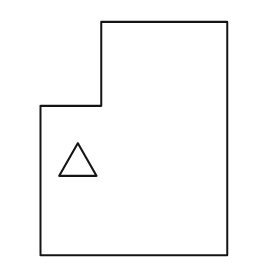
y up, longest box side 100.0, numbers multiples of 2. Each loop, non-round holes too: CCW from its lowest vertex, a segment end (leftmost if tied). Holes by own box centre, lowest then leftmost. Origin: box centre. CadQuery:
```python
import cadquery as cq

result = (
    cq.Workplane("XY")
    .moveTo(-40.0, -50.0)
    .lineTo(40.0, -50.0)
    .lineTo(40.0, 50.0)
    .lineTo(-14.0, 50.0)
    .lineTo(-14.0, 14.0)
    .lineTo(-40.0, 14.0)
    .close()
    .moveTo(-32.0, -16.0)
    .lineTo(-16.0, -16.0)
    .lineTo(-24.0, -2.0)
    .close()
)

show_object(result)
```